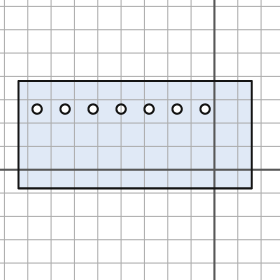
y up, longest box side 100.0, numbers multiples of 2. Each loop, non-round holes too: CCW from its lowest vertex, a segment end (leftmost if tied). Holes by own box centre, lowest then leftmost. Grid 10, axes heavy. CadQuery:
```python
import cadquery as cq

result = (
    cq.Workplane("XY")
    .moveTo(-84.0, -8.0)
    .lineTo(16.0, -8.0)
    .lineTo(16.0, 38.0)
    .lineTo(-84.0, 38.0)
    .close()
    .moveTo(-76.0, 26.0)
    .circle(2.0)
    .moveTo(-64.0, 26.0)
    .circle(2.0)
    .moveTo(-52.0, 26.0)
    .circle(2.0)
    .moveTo(-40.0, 26.0)
    .circle(2.0)
    .moveTo(-28.0, 26.0)
    .circle(2.0)
    .moveTo(-16.0, 26.0)
    .circle(2.0)
    .moveTo(-4.0, 26.0)
    .circle(2.0)
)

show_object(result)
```